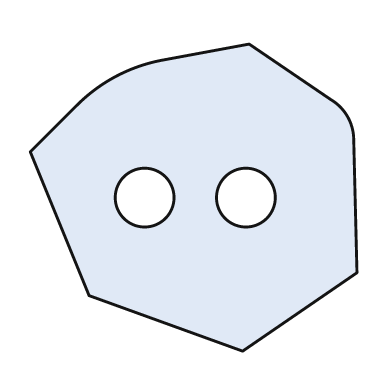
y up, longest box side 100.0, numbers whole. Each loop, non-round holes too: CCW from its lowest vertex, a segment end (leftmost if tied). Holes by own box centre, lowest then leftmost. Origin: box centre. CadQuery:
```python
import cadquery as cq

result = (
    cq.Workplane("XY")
    .moveTo(15.0, -47.0)
    .lineTo(50.0, -23.0)
    .lineTo(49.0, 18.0)
    .threePointArc((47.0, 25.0), (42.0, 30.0))
    .lineTo(17.0, 47.0)
    .lineTo(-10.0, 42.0)
    .threePointArc((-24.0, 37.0), (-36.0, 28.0))
    .lineTo(-50.0, 14.0)
    .lineTo(-32.0, -30.0)
    .close()
    .moveTo(-15.0, 0.0)
    .circle(9.0)
    .moveTo(16.0, 0.0)
    .circle(9.0)
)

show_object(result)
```